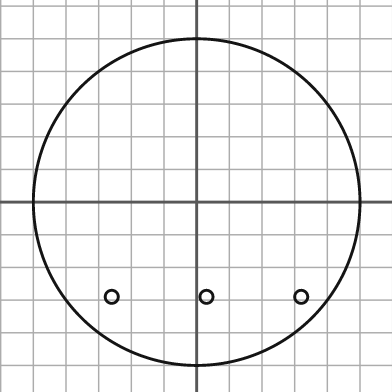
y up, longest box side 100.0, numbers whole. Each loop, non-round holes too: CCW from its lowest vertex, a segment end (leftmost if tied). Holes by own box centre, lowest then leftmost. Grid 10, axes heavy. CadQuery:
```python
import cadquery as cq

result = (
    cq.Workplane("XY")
    .moveTo(0.0, 0.0)
    .circle(50.0)
    .moveTo(-26.0, -29.0)
    .circle(2.0)
    .moveTo(3.0, -29.0)
    .circle(2.0)
    .moveTo(32.0, -29.0)
    .circle(2.0)
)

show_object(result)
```